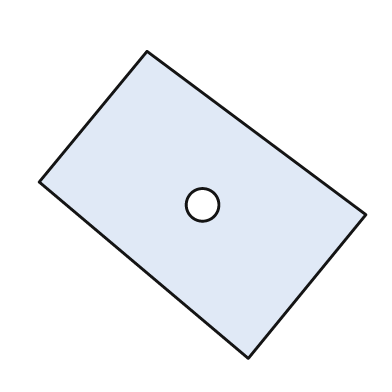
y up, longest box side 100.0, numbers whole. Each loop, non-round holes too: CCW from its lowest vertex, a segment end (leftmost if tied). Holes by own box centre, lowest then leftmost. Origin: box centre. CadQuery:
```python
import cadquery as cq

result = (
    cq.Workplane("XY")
    .moveTo(14.0, -47.0)
    .lineTo(50.0, -3.0)
    .lineTo(-17.0, 47.0)
    .lineTo(-50.0, 7.0)
    .close()
    .moveTo(0.0, 0.0)
    .circle(5.0)
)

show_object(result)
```